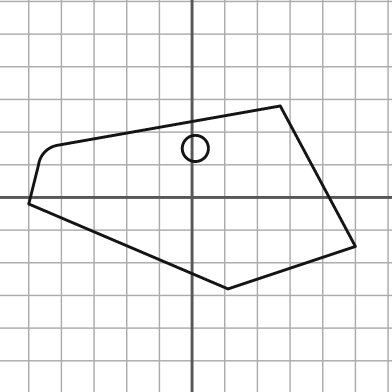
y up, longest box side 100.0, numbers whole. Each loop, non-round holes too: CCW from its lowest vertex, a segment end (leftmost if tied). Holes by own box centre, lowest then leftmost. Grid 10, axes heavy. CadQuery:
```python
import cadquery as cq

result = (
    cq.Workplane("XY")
    .moveTo(11.0, -28.0)
    .lineTo(50.0, -15.0)
    .lineTo(27.0, 28.0)
    .lineTo(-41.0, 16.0)
    .threePointArc((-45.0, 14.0), (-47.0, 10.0))
    .lineTo(-50.0, -2.0)
    .close()
    .moveTo(1.0, 15.0)
    .circle(4.0)
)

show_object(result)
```